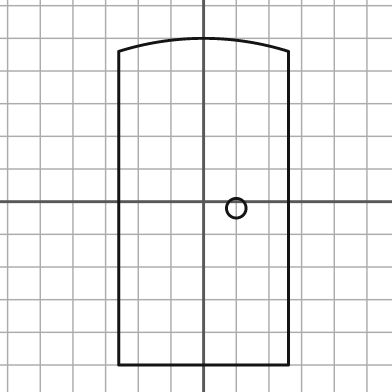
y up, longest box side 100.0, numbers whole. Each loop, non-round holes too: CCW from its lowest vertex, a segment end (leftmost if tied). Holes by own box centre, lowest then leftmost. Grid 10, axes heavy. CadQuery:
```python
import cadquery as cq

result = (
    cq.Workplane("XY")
    .moveTo(-26.0, -50.0)
    .lineTo(26.0, -50.0)
    .lineTo(26.0, 46.0)
    .threePointArc((0.0, 50.0), (-26.0, 46.0))
    .close()
    .moveTo(10.0, -2.0)
    .circle(3.0)
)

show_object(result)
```